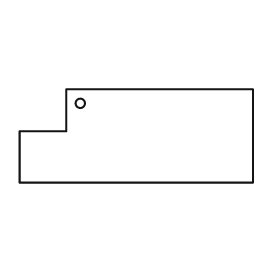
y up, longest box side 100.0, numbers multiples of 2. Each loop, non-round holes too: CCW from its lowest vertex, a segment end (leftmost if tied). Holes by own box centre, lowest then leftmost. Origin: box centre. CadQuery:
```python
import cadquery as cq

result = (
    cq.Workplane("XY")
    .moveTo(-50.0, -20.0)
    .lineTo(50.0, -20.0)
    .lineTo(50.0, 20.0)
    .lineTo(-30.0, 20.0)
    .lineTo(-30.0, 2.0)
    .lineTo(-50.0, 2.0)
    .close()
    .moveTo(-24.0, 14.0)
    .circle(2.0)
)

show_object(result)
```